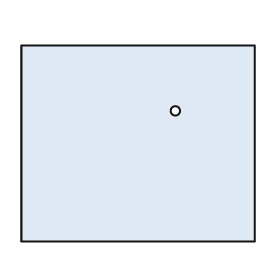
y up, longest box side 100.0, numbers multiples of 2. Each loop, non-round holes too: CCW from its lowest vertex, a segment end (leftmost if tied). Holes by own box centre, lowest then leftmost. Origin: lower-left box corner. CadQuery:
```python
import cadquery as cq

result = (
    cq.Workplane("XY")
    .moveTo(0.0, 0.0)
    .lineTo(100.0, 0.0)
    .lineTo(100.0, 84.0)
    .lineTo(0.0, 84.0)
    .close()
    .moveTo(66.0, 56.0)
    .circle(2.0)
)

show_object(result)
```